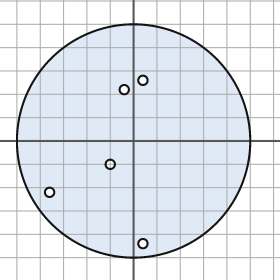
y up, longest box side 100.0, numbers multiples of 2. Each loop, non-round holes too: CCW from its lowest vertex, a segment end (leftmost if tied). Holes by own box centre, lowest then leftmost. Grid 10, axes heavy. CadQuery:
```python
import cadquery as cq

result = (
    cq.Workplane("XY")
    .moveTo(0.0, 0.0)
    .circle(50.0)
    .moveTo(4.0, -44.0)
    .circle(2.0)
    .moveTo(-36.0, -22.0)
    .circle(2.0)
    .moveTo(-10.0, -10.0)
    .circle(2.0)
    .moveTo(-4.0, 22.0)
    .circle(2.0)
    .moveTo(4.0, 26.0)
    .circle(2.0)
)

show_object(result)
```